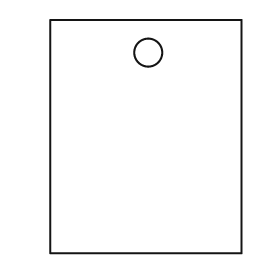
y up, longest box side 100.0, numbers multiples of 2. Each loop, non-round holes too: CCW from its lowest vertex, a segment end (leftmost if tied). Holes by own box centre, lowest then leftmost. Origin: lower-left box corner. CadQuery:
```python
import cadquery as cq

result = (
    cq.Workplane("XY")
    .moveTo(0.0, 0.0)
    .lineTo(82.0, 0.0)
    .lineTo(82.0, 100.0)
    .lineTo(0.0, 100.0)
    .close()
    .moveTo(42.0, 86.0)
    .circle(6.0)
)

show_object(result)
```